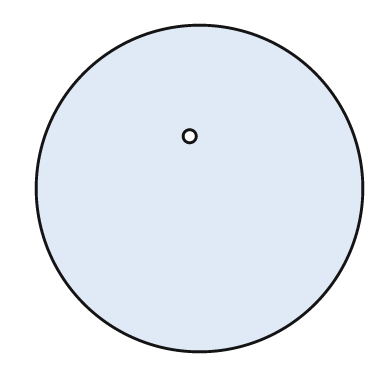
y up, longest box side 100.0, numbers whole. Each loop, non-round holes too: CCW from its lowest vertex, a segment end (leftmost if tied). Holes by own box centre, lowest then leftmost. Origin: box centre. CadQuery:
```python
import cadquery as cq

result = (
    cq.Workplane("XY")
    .moveTo(0.0, 0.0)
    .circle(50.0)
    .moveTo(-3.0, 16.0)
    .circle(2.0)
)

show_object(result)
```